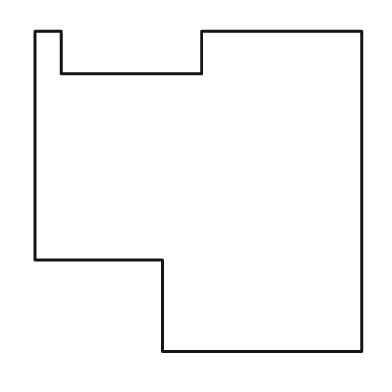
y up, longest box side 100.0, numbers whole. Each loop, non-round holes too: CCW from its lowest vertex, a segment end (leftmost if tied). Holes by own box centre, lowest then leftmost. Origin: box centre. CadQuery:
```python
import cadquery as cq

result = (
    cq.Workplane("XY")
    .moveTo(-11.0, -49.0)
    .lineTo(50.0, -49.0)
    .lineTo(50.0, 49.0)
    .lineTo(1.0, 49.0)
    .lineTo(1.0, 36.0)
    .lineTo(-42.0, 36.0)
    .lineTo(-42.0, 49.0)
    .lineTo(-50.0, 49.0)
    .lineTo(-50.0, -21.0)
    .lineTo(-11.0, -21.0)
    .close()
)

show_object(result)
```